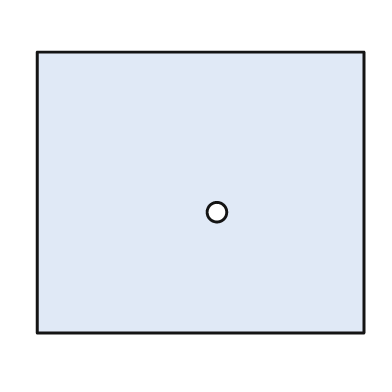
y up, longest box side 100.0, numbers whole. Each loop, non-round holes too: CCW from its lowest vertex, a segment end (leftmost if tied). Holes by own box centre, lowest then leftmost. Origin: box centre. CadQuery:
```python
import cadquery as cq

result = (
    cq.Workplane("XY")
    .moveTo(-50.0, -43.0)
    .lineTo(50.0, -43.0)
    .lineTo(50.0, 43.0)
    .lineTo(-50.0, 43.0)
    .close()
    .moveTo(5.0, -6.0)
    .circle(3.0)
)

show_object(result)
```